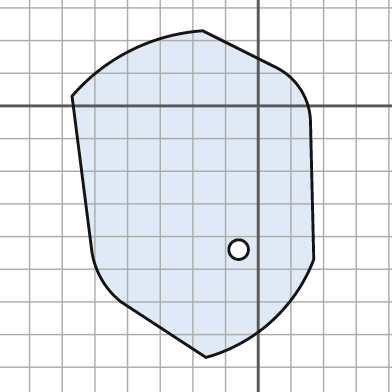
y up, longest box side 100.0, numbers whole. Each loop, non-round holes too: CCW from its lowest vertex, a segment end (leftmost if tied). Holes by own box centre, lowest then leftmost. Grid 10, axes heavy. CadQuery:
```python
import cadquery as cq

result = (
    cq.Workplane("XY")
    .moveTo(-16.0, -77.0)
    .threePointArc((4.0, -66.0), (17.0, -47.0))
    .lineTo(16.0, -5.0)
    .threePointArc((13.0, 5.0), (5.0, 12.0))
    .lineTo(-17.0, 23.0)
    .threePointArc((-39.0, 17.0), (-57.0, 3.0))
    .lineTo(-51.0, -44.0)
    .threePointArc((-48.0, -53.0), (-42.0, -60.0))
    .close()
    .moveTo(-6.0, -44.0)
    .circle(3.0)
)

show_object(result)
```